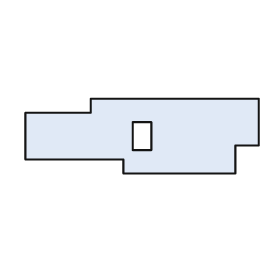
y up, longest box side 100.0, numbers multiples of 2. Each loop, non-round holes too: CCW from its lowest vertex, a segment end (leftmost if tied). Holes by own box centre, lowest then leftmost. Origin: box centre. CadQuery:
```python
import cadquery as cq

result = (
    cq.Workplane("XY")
    .moveTo(-8.0, -16.0)
    .lineTo(40.0, -16.0)
    .lineTo(40.0, -4.0)
    .lineTo(50.0, -4.0)
    .lineTo(50.0, 16.0)
    .lineTo(-22.0, 16.0)
    .lineTo(-22.0, 10.0)
    .lineTo(-50.0, 10.0)
    .lineTo(-50.0, -10.0)
    .lineTo(-8.0, -10.0)
    .close()
    .moveTo(-4.0, -6.0)
    .lineTo(4.0, -6.0)
    .lineTo(4.0, 6.0)
    .lineTo(-4.0, 6.0)
    .close()
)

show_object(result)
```